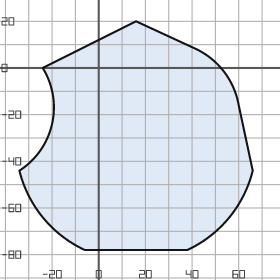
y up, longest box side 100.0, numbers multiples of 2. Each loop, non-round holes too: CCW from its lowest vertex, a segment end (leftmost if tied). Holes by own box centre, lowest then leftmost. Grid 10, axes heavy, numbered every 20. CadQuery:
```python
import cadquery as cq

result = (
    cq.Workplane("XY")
    .moveTo(-6.0, -78.0)
    .lineTo(38.0, -78.0)
    .threePointArc((56.0, -64.0), (66.0, -44.0))
    .lineTo(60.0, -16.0)
    .threePointArc((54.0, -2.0), (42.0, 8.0))
    .lineTo(16.0, 20.0)
    .lineTo(-24.0, 0.0)
    .threePointArc((-20.0, -24.0), (-34.0, -44.0))
    .threePointArc((-24.0, -64.0), (-6.0, -78.0))
    .close()
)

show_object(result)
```